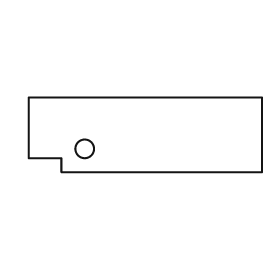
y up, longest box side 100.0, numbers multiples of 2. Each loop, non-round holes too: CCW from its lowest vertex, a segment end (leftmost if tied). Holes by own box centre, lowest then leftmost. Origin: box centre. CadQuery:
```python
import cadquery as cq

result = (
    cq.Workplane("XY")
    .moveTo(-36.0, -16.0)
    .lineTo(50.0, -16.0)
    .lineTo(50.0, 16.0)
    .lineTo(-50.0, 16.0)
    .lineTo(-50.0, -10.0)
    .lineTo(-36.0, -10.0)
    .close()
    .moveTo(-26.0, -6.0)
    .circle(4.0)
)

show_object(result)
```